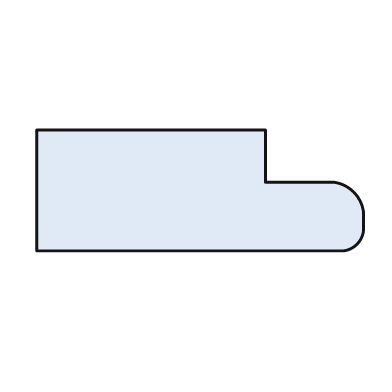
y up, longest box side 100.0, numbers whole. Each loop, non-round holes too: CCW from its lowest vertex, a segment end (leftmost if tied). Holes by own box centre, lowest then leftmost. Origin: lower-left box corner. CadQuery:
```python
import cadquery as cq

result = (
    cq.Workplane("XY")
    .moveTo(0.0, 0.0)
    .lineTo(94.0, 0.0)
    .threePointArc((98.0, 2.0), (100.0, 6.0))
    .lineTo(100.0, 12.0)
    .threePointArc((97.0, 18.0), (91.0, 21.0))
    .lineTo(70.0, 21.0)
    .lineTo(70.0, 37.0)
    .lineTo(0.0, 37.0)
    .close()
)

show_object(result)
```